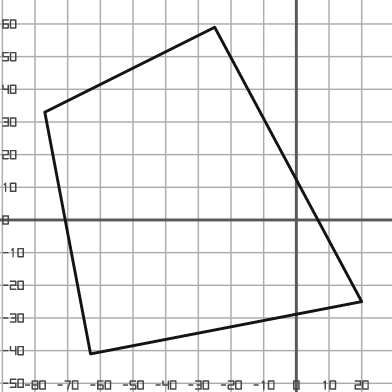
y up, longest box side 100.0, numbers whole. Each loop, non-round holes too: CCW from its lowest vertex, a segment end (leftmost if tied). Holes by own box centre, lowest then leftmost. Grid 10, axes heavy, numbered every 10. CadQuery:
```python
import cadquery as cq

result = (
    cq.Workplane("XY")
    .moveTo(-63.0, -41.0)
    .lineTo(20.0, -25.0)
    .lineTo(-25.0, 59.0)
    .lineTo(-77.0, 33.0)
    .close()
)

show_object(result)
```